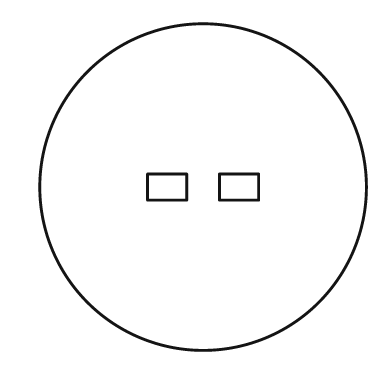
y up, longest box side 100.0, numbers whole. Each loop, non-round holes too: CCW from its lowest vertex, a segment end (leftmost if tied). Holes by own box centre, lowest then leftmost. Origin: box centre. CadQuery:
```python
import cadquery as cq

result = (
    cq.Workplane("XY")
    .moveTo(0.0, 0.0)
    .circle(50.0)
    .moveTo(-17.0, -4.0)
    .lineTo(-5.0, -4.0)
    .lineTo(-5.0, 4.0)
    .lineTo(-17.0, 4.0)
    .close()
    .moveTo(5.0, -4.0)
    .lineTo(17.0, -4.0)
    .lineTo(17.0, 4.0)
    .lineTo(5.0, 4.0)
    .close()
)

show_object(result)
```